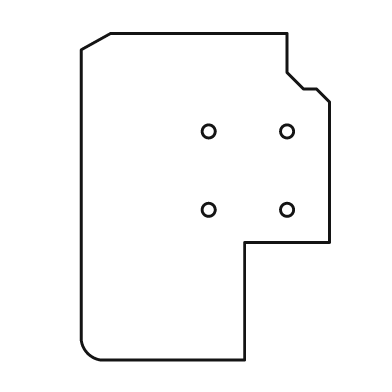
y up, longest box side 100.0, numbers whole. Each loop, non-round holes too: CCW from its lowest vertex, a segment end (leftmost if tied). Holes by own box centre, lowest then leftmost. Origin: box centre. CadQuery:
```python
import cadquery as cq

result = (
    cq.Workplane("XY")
    .moveTo(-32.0, -50.0)
    .lineTo(12.0, -50.0)
    .lineTo(12.0, -14.0)
    .lineTo(38.0, -14.0)
    .lineTo(38.0, 29.0)
    .lineTo(34.0, 33.0)
    .lineTo(30.0, 33.0)
    .lineTo(25.0, 38.0)
    .lineTo(25.0, 50.0)
    .lineTo(-29.0, 50.0)
    .lineTo(-38.0, 45.0)
    .lineTo(-38.0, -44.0)
    .threePointArc((-36.0, -48.0), (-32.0, -50.0))
    .close()
    .moveTo(1.0, -4.0)
    .circle(2.0)
    .moveTo(25.0, -4.0)
    .circle(2.0)
    .moveTo(1.0, 20.0)
    .circle(2.0)
    .moveTo(25.0, 20.0)
    .circle(2.0)
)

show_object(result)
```